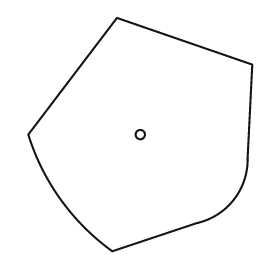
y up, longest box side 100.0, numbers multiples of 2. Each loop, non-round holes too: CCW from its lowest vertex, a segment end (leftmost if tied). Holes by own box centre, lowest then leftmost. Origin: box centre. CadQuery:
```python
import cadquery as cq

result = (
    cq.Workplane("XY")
    .moveTo(-12.0, -50.0)
    .lineTo(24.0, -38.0)
    .threePointArc((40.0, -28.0), (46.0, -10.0))
    .lineTo(48.0, 30.0)
    .lineTo(-10.0, 50.0)
    .lineTo(-48.0, 0.0)
    .threePointArc((-34.0, -28.0), (-12.0, -50.0))
    .close()
    .moveTo(0.0, 0.0)
    .circle(2.0)
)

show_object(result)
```